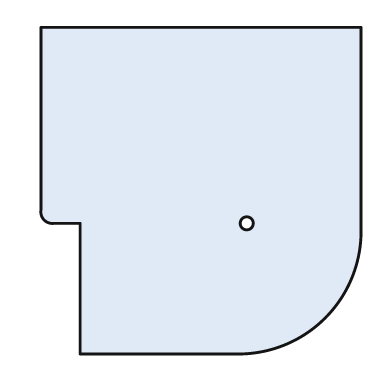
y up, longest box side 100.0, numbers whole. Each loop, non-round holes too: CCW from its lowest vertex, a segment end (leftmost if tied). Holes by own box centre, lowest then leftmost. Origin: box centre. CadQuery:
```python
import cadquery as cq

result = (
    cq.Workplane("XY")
    .moveTo(-37.0, -50.0)
    .lineTo(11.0, -50.0)
    .threePointArc((38.0, -39.0), (49.0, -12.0))
    .lineTo(49.0, 50.0)
    .lineTo(-49.0, 50.0)
    .lineTo(-49.0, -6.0)
    .threePointArc((-48.0, -9.0), (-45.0, -10.0))
    .lineTo(-37.0, -10.0)
    .close()
    .moveTo(14.0, -10.0)
    .circle(2.0)
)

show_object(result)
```